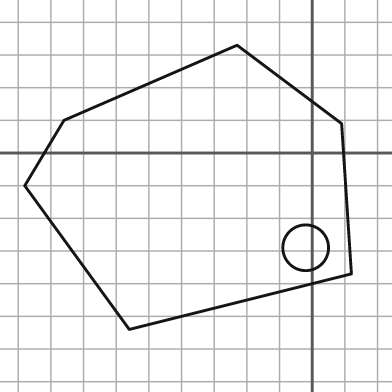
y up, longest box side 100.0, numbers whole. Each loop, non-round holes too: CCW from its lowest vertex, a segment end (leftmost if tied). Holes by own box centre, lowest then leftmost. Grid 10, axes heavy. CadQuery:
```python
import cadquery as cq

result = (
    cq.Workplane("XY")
    .moveTo(-56.0, -54.0)
    .lineTo(12.0, -37.0)
    .lineTo(9.0, 9.0)
    .lineTo(-23.0, 33.0)
    .lineTo(-76.0, 10.0)
    .lineTo(-88.0, -10.0)
    .close()
    .moveTo(-2.0, -29.0)
    .circle(7.0)
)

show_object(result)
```